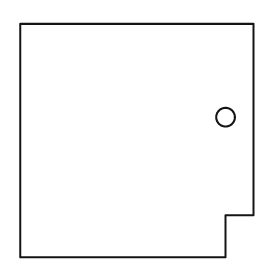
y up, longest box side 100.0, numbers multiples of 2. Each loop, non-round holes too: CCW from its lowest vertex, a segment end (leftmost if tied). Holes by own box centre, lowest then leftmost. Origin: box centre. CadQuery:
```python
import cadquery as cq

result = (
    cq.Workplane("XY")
    .moveTo(-50.0, -50.0)
    .lineTo(38.0, -50.0)
    .lineTo(38.0, -32.0)
    .lineTo(50.0, -32.0)
    .lineTo(50.0, 50.0)
    .lineTo(-50.0, 50.0)
    .close()
    .moveTo(38.0, 10.0)
    .circle(4.0)
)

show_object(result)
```